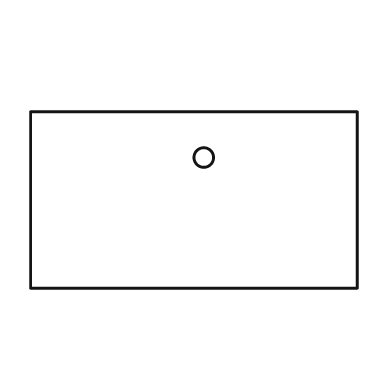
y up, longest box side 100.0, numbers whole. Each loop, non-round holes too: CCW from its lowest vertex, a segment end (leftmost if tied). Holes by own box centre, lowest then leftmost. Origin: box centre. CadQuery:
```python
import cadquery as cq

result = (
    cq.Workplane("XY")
    .moveTo(-50.0, -27.0)
    .lineTo(50.0, -27.0)
    .lineTo(50.0, 27.0)
    .lineTo(-50.0, 27.0)
    .close()
    .moveTo(3.0, 13.0)
    .circle(3.0)
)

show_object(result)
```